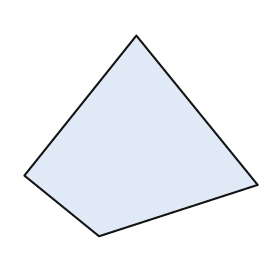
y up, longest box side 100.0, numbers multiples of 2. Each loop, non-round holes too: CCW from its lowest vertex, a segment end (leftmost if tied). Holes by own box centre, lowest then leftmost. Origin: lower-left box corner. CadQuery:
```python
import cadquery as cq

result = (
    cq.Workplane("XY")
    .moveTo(32.0, 0.0)
    .lineTo(100.0, 22.0)
    .lineTo(48.0, 86.0)
    .lineTo(0.0, 26.0)
    .close()
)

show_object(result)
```